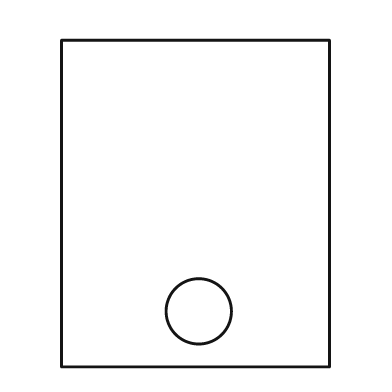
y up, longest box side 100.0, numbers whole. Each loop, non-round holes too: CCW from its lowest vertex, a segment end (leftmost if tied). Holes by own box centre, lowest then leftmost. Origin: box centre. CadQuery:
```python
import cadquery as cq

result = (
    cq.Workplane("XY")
    .moveTo(-41.0, -50.0)
    .lineTo(41.0, -50.0)
    .lineTo(41.0, 50.0)
    .lineTo(-41.0, 50.0)
    .close()
    .moveTo(1.0, -33.0)
    .circle(10.0)
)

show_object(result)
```